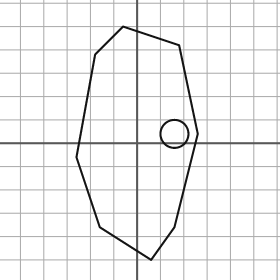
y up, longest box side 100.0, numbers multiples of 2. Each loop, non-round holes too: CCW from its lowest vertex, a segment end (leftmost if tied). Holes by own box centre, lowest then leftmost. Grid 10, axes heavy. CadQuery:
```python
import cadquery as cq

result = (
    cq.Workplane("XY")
    .moveTo(6.0, -50.0)
    .lineTo(16.0, -36.0)
    .lineTo(26.0, 4.0)
    .lineTo(18.0, 42.0)
    .lineTo(-6.0, 50.0)
    .lineTo(-18.0, 38.0)
    .lineTo(-26.0, -6.0)
    .lineTo(-16.0, -36.0)
    .close()
    .moveTo(16.0, 4.0)
    .circle(6.0)
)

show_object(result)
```